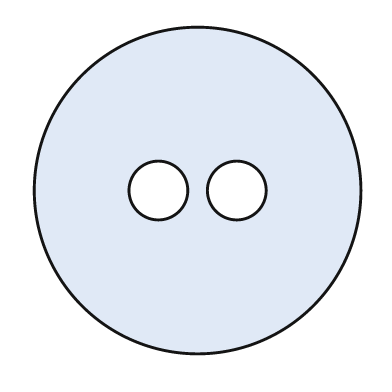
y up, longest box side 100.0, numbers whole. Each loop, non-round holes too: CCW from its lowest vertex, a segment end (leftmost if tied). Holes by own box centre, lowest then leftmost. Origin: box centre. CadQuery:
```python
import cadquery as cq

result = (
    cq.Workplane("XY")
    .moveTo(0.0, 0.0)
    .circle(50.0)
    .moveTo(-12.0, 0.0)
    .circle(9.0)
    .moveTo(12.0, 0.0)
    .circle(9.0)
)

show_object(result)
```